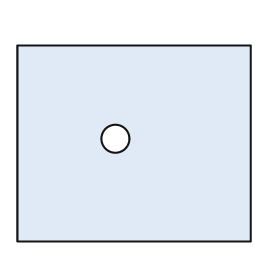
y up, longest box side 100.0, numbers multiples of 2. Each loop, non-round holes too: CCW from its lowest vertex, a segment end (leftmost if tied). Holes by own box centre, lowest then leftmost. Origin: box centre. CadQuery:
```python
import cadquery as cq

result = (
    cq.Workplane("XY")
    .moveTo(-50.0, -42.0)
    .lineTo(50.0, -42.0)
    .lineTo(50.0, 42.0)
    .lineTo(-50.0, 42.0)
    .close()
    .moveTo(-8.0, 2.0)
    .circle(6.0)
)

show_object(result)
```